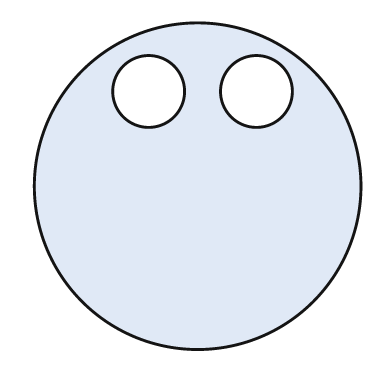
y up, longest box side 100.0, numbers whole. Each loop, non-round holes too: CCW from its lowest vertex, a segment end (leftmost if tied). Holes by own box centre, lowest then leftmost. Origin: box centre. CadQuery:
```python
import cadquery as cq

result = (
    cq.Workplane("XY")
    .moveTo(0.0, 0.0)
    .circle(50.0)
    .moveTo(-15.0, 29.0)
    .circle(11.0)
    .moveTo(18.0, 29.0)
    .circle(11.0)
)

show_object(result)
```